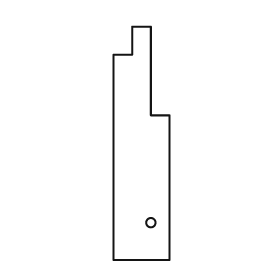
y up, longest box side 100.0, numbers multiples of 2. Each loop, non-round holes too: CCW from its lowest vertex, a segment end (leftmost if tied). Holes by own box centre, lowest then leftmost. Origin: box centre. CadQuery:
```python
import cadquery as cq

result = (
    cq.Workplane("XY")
    .moveTo(-12.0, -50.0)
    .lineTo(12.0, -50.0)
    .lineTo(12.0, 12.0)
    .lineTo(4.0, 12.0)
    .lineTo(4.0, 50.0)
    .lineTo(-4.0, 50.0)
    .lineTo(-4.0, 38.0)
    .lineTo(-12.0, 38.0)
    .close()
    .moveTo(4.0, -34.0)
    .circle(2.0)
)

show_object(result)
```